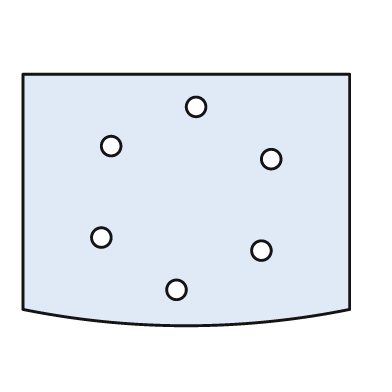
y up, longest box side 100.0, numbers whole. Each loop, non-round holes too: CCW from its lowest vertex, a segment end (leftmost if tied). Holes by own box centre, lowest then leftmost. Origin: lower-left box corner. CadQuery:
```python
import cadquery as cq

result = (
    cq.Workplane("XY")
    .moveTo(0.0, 5.0)
    .threePointArc((50.0, 0.0), (100.0, 5.0))
    .lineTo(100.0, 77.0)
    .lineTo(0.0, 77.0)
    .close()
    .moveTo(47.0, 11.0)
    .circle(3.0)
    .moveTo(73.0, 23.0)
    .circle(3.0)
    .moveTo(24.0, 27.0)
    .circle(3.0)
    .moveTo(76.0, 51.0)
    .circle(3.0)
    .moveTo(27.0, 55.0)
    .circle(3.0)
    .moveTo(53.0, 67.0)
    .circle(3.0)
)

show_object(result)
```